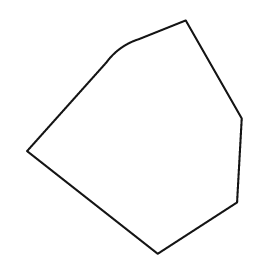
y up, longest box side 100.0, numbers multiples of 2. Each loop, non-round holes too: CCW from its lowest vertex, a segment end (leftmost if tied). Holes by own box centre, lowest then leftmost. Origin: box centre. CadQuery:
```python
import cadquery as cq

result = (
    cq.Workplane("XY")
    .moveTo(10.0, -50.0)
    .lineTo(44.0, -28.0)
    .lineTo(46.0, 8.0)
    .lineTo(22.0, 50.0)
    .lineTo(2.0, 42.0)
    .threePointArc((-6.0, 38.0), (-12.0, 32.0))
    .lineTo(-46.0, -6.0)
    .close()
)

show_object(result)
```